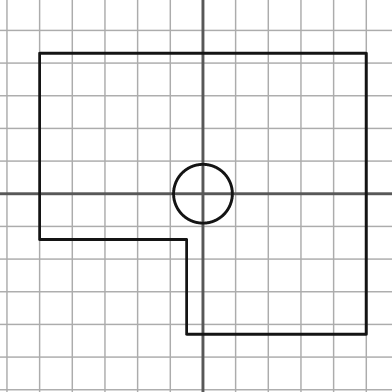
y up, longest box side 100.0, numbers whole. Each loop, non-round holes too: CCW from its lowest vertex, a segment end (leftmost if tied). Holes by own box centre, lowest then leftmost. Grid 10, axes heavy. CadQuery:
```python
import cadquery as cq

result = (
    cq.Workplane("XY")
    .moveTo(-5.0, -43.0)
    .lineTo(50.0, -43.0)
    .lineTo(50.0, 43.0)
    .lineTo(-50.0, 43.0)
    .lineTo(-50.0, -14.0)
    .lineTo(-5.0, -14.0)
    .close()
    .moveTo(0.0, 0.0)
    .circle(9.0)
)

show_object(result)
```